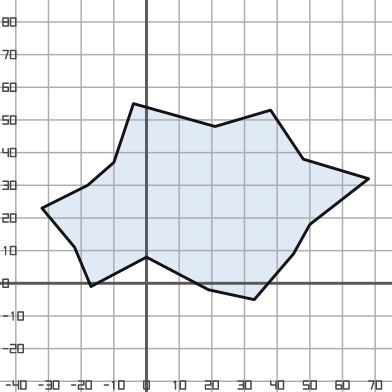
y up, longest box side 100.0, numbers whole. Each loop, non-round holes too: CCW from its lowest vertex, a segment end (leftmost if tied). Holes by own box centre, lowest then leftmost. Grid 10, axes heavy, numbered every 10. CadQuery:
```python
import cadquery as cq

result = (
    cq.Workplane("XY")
    .moveTo(33.0, -5.0)
    .lineTo(45.0, 9.0)
    .lineTo(50.0, 18.0)
    .lineTo(68.0, 32.0)
    .lineTo(48.0, 38.0)
    .lineTo(38.0, 53.0)
    .lineTo(21.0, 48.0)
    .lineTo(-4.0, 55.0)
    .lineTo(-10.0, 37.0)
    .lineTo(-18.0, 30.0)
    .lineTo(-32.0, 23.0)
    .lineTo(-22.0, 11.0)
    .lineTo(-17.0, -1.0)
    .lineTo(0.0, 8.0)
    .lineTo(19.0, -2.0)
    .close()
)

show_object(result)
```